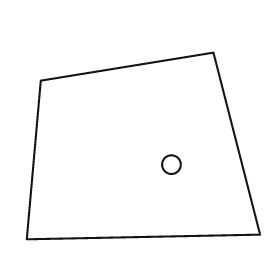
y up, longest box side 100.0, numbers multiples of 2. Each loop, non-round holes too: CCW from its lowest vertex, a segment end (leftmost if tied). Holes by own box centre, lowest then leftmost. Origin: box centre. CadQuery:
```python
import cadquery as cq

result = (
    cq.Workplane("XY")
    .moveTo(-50.0, -40.0)
    .lineTo(50.0, -38.0)
    .lineTo(30.0, 40.0)
    .lineTo(-44.0, 28.0)
    .close()
    .moveTo(12.0, -8.0)
    .circle(4.0)
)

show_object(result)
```